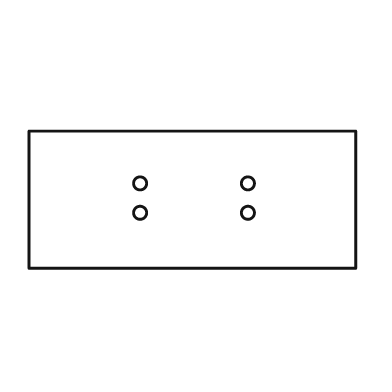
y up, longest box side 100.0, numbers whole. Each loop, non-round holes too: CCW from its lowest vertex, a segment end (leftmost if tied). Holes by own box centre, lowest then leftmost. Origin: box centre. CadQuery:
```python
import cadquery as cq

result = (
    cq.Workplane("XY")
    .moveTo(-50.0, -21.0)
    .lineTo(50.0, -21.0)
    .lineTo(50.0, 21.0)
    .lineTo(-50.0, 21.0)
    .close()
    .moveTo(-16.0, -4.0)
    .circle(2.0)
    .moveTo(17.0, -4.0)
    .circle(2.0)
    .moveTo(-16.0, 5.0)
    .circle(2.0)
    .moveTo(17.0, 5.0)
    .circle(2.0)
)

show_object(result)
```